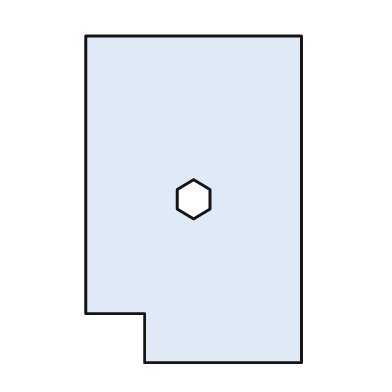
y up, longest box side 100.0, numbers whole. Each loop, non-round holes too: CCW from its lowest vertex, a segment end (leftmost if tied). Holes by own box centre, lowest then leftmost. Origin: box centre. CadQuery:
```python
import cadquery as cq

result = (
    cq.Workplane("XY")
    .moveTo(-15.0, -50.0)
    .lineTo(33.0, -50.0)
    .lineTo(33.0, 50.0)
    .lineTo(-33.0, 50.0)
    .lineTo(-33.0, -35.0)
    .lineTo(-15.0, -35.0)
    .close()
    .moveTo(0.0, -6.0)
    .lineTo(5.0, -3.0)
    .lineTo(5.0, 3.0)
    .lineTo(0.0, 6.0)
    .lineTo(-5.0, 3.0)
    .lineTo(-5.0, -3.0)
    .close()
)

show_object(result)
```